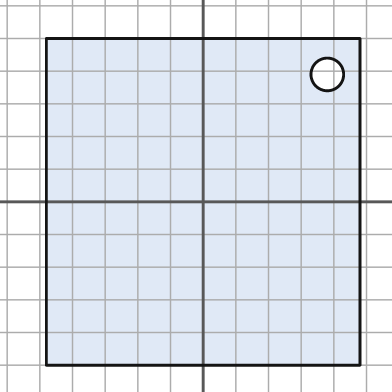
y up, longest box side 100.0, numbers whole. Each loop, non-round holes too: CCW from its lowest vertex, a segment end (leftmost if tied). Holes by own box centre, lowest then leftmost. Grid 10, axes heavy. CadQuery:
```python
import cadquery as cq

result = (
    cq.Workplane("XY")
    .moveTo(-48.0, -50.0)
    .lineTo(48.0, -50.0)
    .lineTo(48.0, 50.0)
    .lineTo(-48.0, 50.0)
    .close()
    .moveTo(38.0, 39.0)
    .circle(5.0)
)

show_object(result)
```